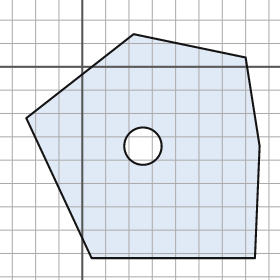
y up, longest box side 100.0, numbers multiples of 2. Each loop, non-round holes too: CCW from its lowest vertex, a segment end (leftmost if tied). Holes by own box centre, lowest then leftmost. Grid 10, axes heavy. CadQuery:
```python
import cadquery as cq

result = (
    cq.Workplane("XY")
    .moveTo(4.0, -82.0)
    .lineTo(74.0, -82.0)
    .lineTo(76.0, -34.0)
    .lineTo(70.0, 4.0)
    .lineTo(22.0, 14.0)
    .lineTo(-24.0, -22.0)
    .close()
    .moveTo(26.0, -34.0)
    .circle(8.0)
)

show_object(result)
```